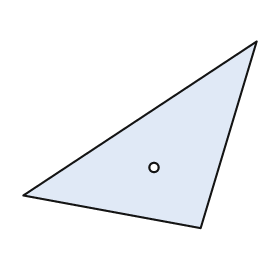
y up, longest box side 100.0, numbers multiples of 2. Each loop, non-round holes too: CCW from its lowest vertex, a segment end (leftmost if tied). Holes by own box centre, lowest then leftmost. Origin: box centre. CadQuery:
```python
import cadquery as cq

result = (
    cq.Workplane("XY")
    .moveTo(26.0, -40.0)
    .lineTo(50.0, 40.0)
    .lineTo(-50.0, -26.0)
    .close()
    .moveTo(6.0, -14.0)
    .circle(2.0)
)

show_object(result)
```